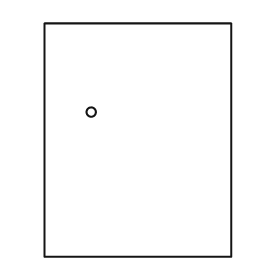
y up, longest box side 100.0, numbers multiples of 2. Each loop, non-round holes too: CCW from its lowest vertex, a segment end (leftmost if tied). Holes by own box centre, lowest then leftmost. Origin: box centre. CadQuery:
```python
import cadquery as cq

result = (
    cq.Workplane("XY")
    .moveTo(-40.0, -50.0)
    .lineTo(40.0, -50.0)
    .lineTo(40.0, 50.0)
    .lineTo(-40.0, 50.0)
    .close()
    .moveTo(-20.0, 12.0)
    .circle(2.0)
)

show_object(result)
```